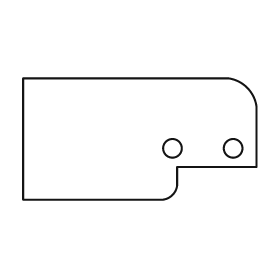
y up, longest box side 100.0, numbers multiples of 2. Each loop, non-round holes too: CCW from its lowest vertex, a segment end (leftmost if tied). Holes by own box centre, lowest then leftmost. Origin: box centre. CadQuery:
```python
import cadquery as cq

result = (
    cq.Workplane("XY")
    .moveTo(-50.0, -26.0)
    .lineTo(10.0, -26.0)
    .threePointArc((14.0, -24.0), (16.0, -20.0))
    .lineTo(16.0, -12.0)
    .lineTo(50.0, -12.0)
    .lineTo(50.0, 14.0)
    .threePointArc((46.0, 22.0), (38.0, 26.0))
    .lineTo(-50.0, 26.0)
    .close()
    .moveTo(14.0, -4.0)
    .circle(4.0)
    .moveTo(40.0, -4.0)
    .circle(4.0)
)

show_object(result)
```